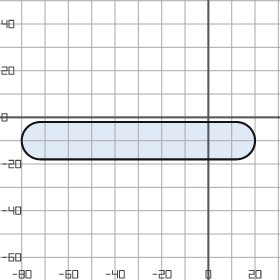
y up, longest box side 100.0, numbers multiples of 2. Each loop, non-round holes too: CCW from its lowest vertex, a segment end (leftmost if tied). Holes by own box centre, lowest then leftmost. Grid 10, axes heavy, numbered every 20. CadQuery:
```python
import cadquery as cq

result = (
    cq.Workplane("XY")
    .moveTo(-72.0, -18.0)
    .lineTo(12.0, -18.0)
    .threePointArc((20.0, -10.0), (12.0, -2.0))
    .lineTo(-72.0, -2.0)
    .threePointArc((-80.0, -10.0), (-72.0, -18.0))
    .close()
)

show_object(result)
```